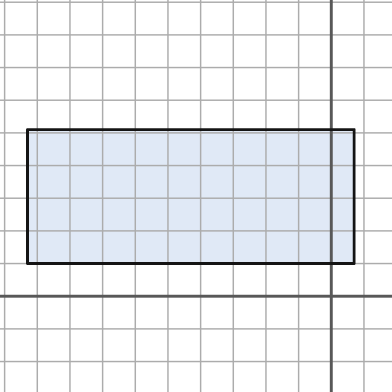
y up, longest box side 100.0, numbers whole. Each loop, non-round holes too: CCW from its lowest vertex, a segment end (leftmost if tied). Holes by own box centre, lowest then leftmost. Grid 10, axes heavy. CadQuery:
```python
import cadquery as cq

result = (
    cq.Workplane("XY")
    .moveTo(-93.0, 10.0)
    .lineTo(7.0, 10.0)
    .lineTo(7.0, 51.0)
    .lineTo(-93.0, 51.0)
    .close()
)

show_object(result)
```